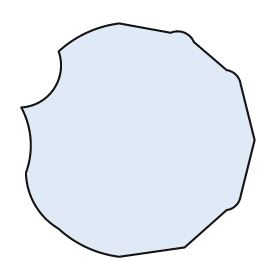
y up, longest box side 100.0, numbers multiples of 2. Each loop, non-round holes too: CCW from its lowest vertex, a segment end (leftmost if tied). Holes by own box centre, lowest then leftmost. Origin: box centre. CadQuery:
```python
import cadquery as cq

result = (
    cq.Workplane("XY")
    .moveTo(-8.0, -50.0)
    .lineTo(20.0, -46.0)
    .lineTo(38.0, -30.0)
    .threePointArc((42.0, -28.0), (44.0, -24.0))
    .lineTo(50.0, 0.0)
    .lineTo(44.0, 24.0)
    .threePointArc((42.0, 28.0), (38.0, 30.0))
    .lineTo(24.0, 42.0)
    .threePointArc((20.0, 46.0), (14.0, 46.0))
    .lineTo(-8.0, 50.0)
    .threePointArc((-22.0, 46.0), (-34.0, 38.0))
    .threePointArc((-36.0, 22.0), (-50.0, 14.0))
    .threePointArc((-46.0, 0.0), (-48.0, -14.0))
    .threePointArc((-44.0, -28.0), (-34.0, -38.0))
    .threePointArc((-22.0, -46.0), (-8.0, -50.0))
    .close()
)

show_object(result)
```